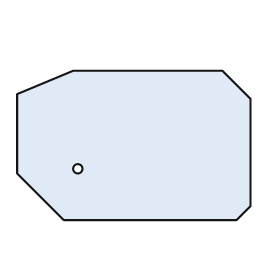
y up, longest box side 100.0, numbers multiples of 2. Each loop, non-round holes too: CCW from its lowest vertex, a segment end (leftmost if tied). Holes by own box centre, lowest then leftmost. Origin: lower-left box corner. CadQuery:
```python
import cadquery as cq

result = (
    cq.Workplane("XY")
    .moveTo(20.0, 0.0)
    .lineTo(94.0, 0.0)
    .lineTo(100.0, 6.0)
    .lineTo(100.0, 52.0)
    .lineTo(88.0, 64.0)
    .lineTo(24.0, 64.0)
    .lineTo(0.0, 54.0)
    .lineTo(0.0, 20.0)
    .close()
    .moveTo(26.0, 22.0)
    .circle(2.0)
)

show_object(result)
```